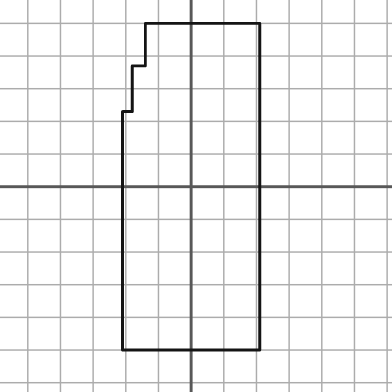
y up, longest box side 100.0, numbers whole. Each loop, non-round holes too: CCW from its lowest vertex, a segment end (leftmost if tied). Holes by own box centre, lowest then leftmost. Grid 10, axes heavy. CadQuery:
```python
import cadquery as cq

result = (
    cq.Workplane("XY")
    .moveTo(-21.0, -50.0)
    .lineTo(21.0, -50.0)
    .lineTo(21.0, 50.0)
    .lineTo(-14.0, 50.0)
    .lineTo(-14.0, 37.0)
    .lineTo(-18.0, 37.0)
    .lineTo(-18.0, 23.0)
    .lineTo(-21.0, 23.0)
    .close()
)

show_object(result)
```